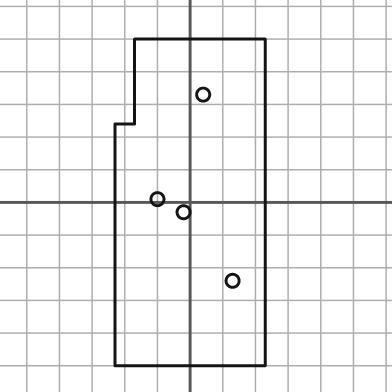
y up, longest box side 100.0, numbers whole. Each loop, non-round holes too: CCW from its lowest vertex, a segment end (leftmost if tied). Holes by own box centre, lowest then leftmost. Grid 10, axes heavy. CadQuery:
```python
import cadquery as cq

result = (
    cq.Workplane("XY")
    .moveTo(-23.0, -50.0)
    .lineTo(23.0, -50.0)
    .lineTo(23.0, 50.0)
    .lineTo(-17.0, 50.0)
    .lineTo(-17.0, 24.0)
    .lineTo(-23.0, 24.0)
    .close()
    .moveTo(13.0, -24.0)
    .circle(2.0)
    .moveTo(-2.0, -3.0)
    .circle(2.0)
    .moveTo(-10.0, 1.0)
    .circle(2.0)
    .moveTo(4.0, 33.0)
    .circle(2.0)
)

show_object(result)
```